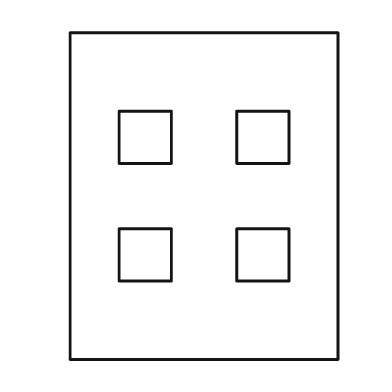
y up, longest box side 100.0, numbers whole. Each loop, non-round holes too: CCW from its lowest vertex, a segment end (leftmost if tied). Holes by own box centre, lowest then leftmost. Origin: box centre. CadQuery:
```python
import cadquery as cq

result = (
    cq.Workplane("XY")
    .moveTo(-41.0, -50.0)
    .lineTo(41.0, -50.0)
    .lineTo(41.0, 50.0)
    .lineTo(-41.0, 50.0)
    .close()
    .moveTo(-26.0, -26.0)
    .lineTo(-10.0, -26.0)
    .lineTo(-10.0, -10.0)
    .lineTo(-26.0, -10.0)
    .close()
    .moveTo(10.0, -26.0)
    .lineTo(26.0, -26.0)
    .lineTo(26.0, -10.0)
    .lineTo(10.0, -10.0)
    .close()
    .moveTo(-26.0, 10.0)
    .lineTo(-10.0, 10.0)
    .lineTo(-10.0, 26.0)
    .lineTo(-26.0, 26.0)
    .close()
    .moveTo(10.0, 10.0)
    .lineTo(26.0, 10.0)
    .lineTo(26.0, 26.0)
    .lineTo(10.0, 26.0)
    .close()
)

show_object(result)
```